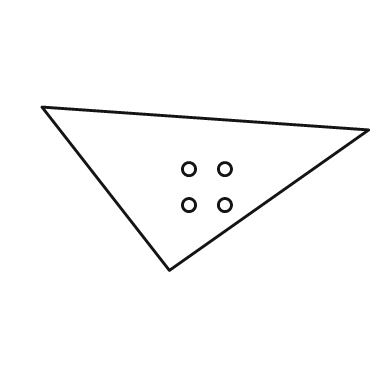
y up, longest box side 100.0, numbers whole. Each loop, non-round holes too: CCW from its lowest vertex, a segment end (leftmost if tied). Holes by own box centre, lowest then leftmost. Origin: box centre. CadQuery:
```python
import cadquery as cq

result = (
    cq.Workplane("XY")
    .moveTo(-11.0, -25.0)
    .lineTo(50.0, 18.0)
    .lineTo(-50.0, 25.0)
    .close()
    .moveTo(-5.0, -5.0)
    .circle(2.0)
    .moveTo(6.0, -5.0)
    .circle(2.0)
    .moveTo(-5.0, 6.0)
    .circle(2.0)
    .moveTo(6.0, 6.0)
    .circle(2.0)
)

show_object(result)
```